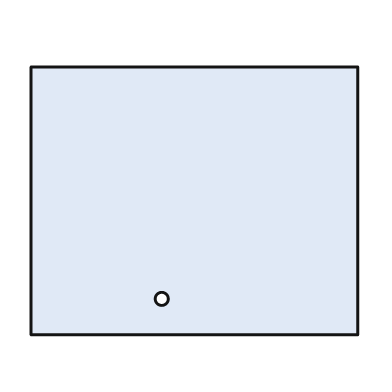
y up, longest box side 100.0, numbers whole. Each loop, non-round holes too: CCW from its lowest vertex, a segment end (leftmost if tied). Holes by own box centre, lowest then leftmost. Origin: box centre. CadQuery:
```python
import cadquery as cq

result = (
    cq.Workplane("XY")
    .moveTo(-50.0, -41.0)
    .lineTo(50.0, -41.0)
    .lineTo(50.0, 41.0)
    .lineTo(-50.0, 41.0)
    .close()
    .moveTo(-10.0, -30.0)
    .circle(2.0)
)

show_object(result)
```